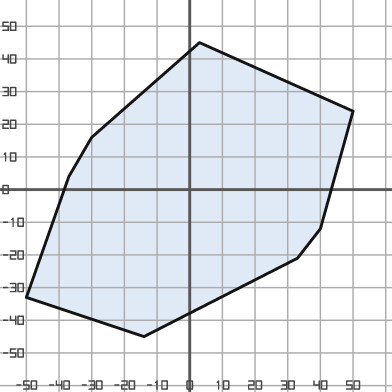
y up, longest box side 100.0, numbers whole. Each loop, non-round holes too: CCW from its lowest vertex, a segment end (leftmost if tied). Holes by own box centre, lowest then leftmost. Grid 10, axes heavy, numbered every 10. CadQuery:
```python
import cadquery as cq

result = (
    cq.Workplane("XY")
    .moveTo(-14.0, -45.0)
    .lineTo(33.0, -21.0)
    .lineTo(40.0, -12.0)
    .lineTo(50.0, 24.0)
    .lineTo(3.0, 45.0)
    .lineTo(-30.0, 16.0)
    .lineTo(-37.0, 4.0)
    .lineTo(-50.0, -33.0)
    .close()
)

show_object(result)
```